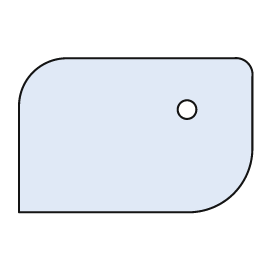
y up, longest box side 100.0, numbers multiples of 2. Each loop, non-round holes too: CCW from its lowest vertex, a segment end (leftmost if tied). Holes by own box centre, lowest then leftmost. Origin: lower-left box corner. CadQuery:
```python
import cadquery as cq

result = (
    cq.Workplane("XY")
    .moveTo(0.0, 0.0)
    .lineTo(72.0, 0.0)
    .threePointArc((92.0, 8.0), (100.0, 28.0))
    .lineTo(100.0, 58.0)
    .threePointArc((98.0, 64.0), (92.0, 66.0))
    .lineTo(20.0, 66.0)
    .threePointArc((6.0, 60.0), (0.0, 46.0))
    .close()
    .moveTo(72.0, 44.0)
    .circle(4.0)
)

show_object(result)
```